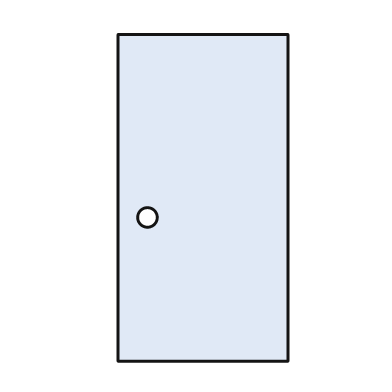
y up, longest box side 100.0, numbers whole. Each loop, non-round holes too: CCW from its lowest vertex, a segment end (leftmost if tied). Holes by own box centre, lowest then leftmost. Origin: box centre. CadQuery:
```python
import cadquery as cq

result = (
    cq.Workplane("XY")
    .moveTo(-26.0, -50.0)
    .lineTo(26.0, -50.0)
    .lineTo(26.0, 50.0)
    .lineTo(-26.0, 50.0)
    .close()
    .moveTo(-17.0, -6.0)
    .circle(3.0)
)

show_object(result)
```